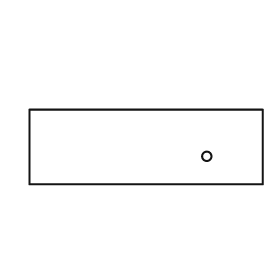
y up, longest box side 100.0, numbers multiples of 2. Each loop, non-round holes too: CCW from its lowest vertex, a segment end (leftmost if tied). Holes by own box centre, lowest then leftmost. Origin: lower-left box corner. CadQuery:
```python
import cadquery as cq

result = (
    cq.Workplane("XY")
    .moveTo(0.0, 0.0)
    .lineTo(100.0, 0.0)
    .lineTo(100.0, 32.0)
    .lineTo(0.0, 32.0)
    .close()
    .moveTo(76.0, 12.0)
    .circle(2.0)
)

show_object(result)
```